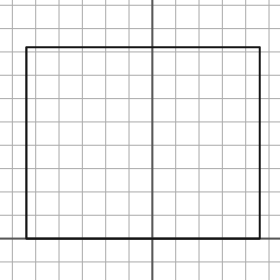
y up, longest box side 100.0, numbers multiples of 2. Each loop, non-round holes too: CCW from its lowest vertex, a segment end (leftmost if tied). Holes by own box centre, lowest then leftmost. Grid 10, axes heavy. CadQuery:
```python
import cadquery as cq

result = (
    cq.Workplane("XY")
    .moveTo(-54.0, 0.0)
    .lineTo(46.0, 0.0)
    .lineTo(46.0, 82.0)
    .lineTo(-54.0, 82.0)
    .close()
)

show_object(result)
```